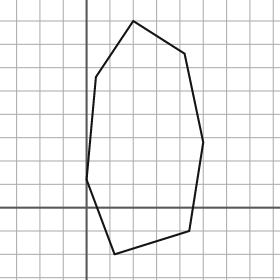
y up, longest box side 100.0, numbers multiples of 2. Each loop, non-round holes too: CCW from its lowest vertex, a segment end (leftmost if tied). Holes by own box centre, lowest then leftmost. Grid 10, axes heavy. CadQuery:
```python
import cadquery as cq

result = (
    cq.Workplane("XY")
    .moveTo(12.0, -20.0)
    .lineTo(44.0, -10.0)
    .lineTo(50.0, 28.0)
    .lineTo(42.0, 66.0)
    .lineTo(20.0, 80.0)
    .lineTo(4.0, 56.0)
    .lineTo(0.0, 12.0)
    .close()
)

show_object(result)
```